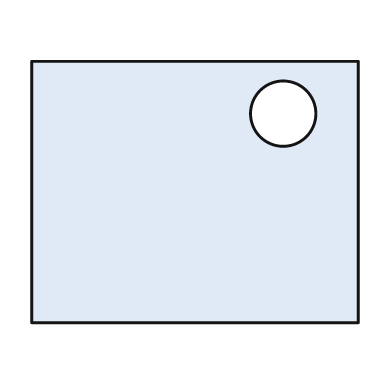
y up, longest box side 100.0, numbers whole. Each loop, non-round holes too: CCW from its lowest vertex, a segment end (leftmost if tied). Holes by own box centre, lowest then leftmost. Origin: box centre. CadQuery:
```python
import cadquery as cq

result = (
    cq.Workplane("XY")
    .moveTo(-50.0, -40.0)
    .lineTo(50.0, -40.0)
    .lineTo(50.0, 40.0)
    .lineTo(-50.0, 40.0)
    .close()
    .moveTo(27.0, 24.0)
    .circle(10.0)
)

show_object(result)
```